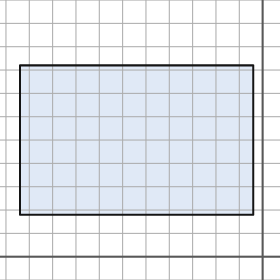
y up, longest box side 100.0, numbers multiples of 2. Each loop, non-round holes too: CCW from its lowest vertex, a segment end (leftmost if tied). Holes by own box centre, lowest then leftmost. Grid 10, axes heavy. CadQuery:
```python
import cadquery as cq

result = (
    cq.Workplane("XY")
    .moveTo(-104.0, 18.0)
    .lineTo(-4.0, 18.0)
    .lineTo(-4.0, 82.0)
    .lineTo(-104.0, 82.0)
    .close()
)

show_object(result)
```